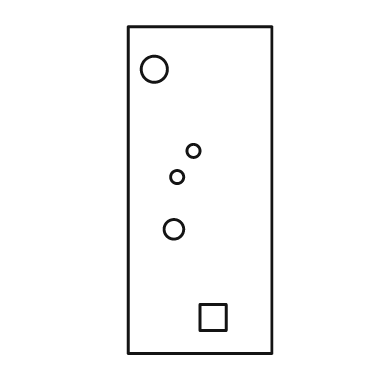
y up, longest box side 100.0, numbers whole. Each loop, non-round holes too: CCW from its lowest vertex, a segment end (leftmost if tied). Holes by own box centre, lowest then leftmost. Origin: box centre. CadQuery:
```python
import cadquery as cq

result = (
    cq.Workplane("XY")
    .moveTo(-22.0, -50.0)
    .lineTo(22.0, -50.0)
    .lineTo(22.0, 50.0)
    .lineTo(-22.0, 50.0)
    .close()
    .moveTo(0.0, -43.0)
    .lineTo(8.0, -43.0)
    .lineTo(8.0, -35.0)
    .lineTo(0.0, -35.0)
    .close()
    .moveTo(-8.0, -12.0)
    .circle(3.0)
    .moveTo(-7.0, 4.0)
    .circle(2.0)
    .moveTo(-2.0, 12.0)
    .circle(2.0)
    .moveTo(-14.0, 37.0)
    .circle(4.0)
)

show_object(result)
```